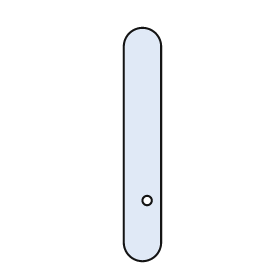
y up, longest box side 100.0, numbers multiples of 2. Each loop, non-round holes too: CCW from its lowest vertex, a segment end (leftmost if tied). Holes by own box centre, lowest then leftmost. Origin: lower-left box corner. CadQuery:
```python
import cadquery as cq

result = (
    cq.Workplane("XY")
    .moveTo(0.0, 8.0)
    .threePointArc((8.0, 0.0), (16.0, 8.0))
    .lineTo(16.0, 92.0)
    .threePointArc((8.0, 100.0), (0.0, 92.0))
    .close()
    .moveTo(10.0, 26.0)
    .circle(2.0)
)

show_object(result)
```